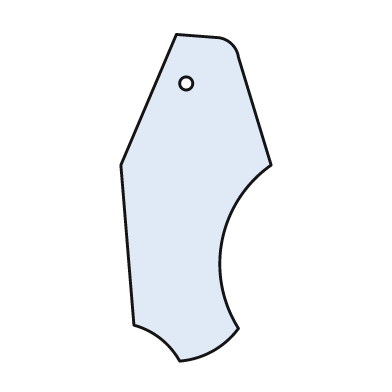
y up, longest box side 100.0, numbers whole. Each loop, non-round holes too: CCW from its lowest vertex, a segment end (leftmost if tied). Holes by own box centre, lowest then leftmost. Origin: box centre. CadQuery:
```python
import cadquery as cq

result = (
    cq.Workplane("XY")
    .moveTo(-5.0, -50.0)
    .threePointArc((5.0, -47.0), (13.0, -40.0))
    .threePointArc((8.0, -13.0), (23.0, 10.0))
    .lineTo(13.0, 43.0)
    .threePointArc((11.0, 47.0), (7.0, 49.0))
    .lineTo(-6.0, 50.0)
    .lineTo(-23.0, 10.0)
    .lineTo(-19.0, -39.0)
    .threePointArc((-11.0, -43.0), (-5.0, -50.0))
    .close()
    .moveTo(-3.0, 35.0)
    .circle(2.0)
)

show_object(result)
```